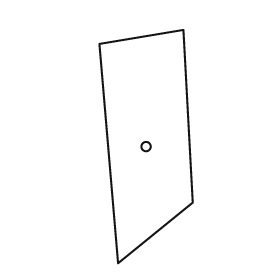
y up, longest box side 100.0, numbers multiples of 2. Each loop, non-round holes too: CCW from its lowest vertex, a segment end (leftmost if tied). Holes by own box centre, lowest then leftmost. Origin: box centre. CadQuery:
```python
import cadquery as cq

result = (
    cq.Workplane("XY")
    .moveTo(-12.0, -50.0)
    .lineTo(20.0, -24.0)
    .lineTo(16.0, 50.0)
    .lineTo(-20.0, 44.0)
    .close()
    .moveTo(0.0, 0.0)
    .circle(2.0)
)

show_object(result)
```